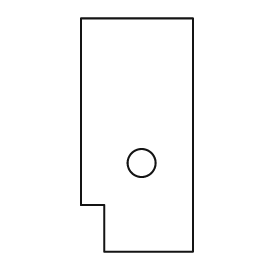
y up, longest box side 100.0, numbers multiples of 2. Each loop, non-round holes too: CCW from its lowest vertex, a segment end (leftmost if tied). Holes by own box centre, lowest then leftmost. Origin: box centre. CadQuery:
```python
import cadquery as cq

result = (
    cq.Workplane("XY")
    .moveTo(-14.0, -50.0)
    .lineTo(24.0, -50.0)
    .lineTo(24.0, 50.0)
    .lineTo(-24.0, 50.0)
    .lineTo(-24.0, -30.0)
    .lineTo(-14.0, -30.0)
    .close()
    .moveTo(2.0, -12.0)
    .circle(6.0)
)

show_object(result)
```